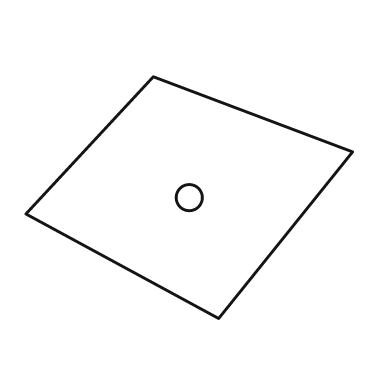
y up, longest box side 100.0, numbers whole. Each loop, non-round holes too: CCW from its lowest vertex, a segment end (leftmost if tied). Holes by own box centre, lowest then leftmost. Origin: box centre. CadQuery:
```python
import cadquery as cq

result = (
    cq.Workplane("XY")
    .moveTo(9.0, -37.0)
    .lineTo(50.0, 14.0)
    .lineTo(-11.0, 37.0)
    .lineTo(-50.0, -5.0)
    .close()
    .moveTo(0.0, 0.0)
    .circle(4.0)
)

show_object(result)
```